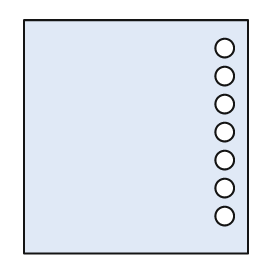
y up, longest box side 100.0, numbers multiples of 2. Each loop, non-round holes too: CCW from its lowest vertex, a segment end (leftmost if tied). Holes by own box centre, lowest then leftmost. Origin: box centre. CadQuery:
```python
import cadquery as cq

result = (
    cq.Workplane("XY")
    .moveTo(-48.0, -50.0)
    .lineTo(48.0, -50.0)
    .lineTo(48.0, 50.0)
    .lineTo(-48.0, 50.0)
    .close()
    .moveTo(38.0, -34.0)
    .circle(4.0)
    .moveTo(38.0, -22.0)
    .circle(4.0)
    .moveTo(38.0, -10.0)
    .circle(4.0)
    .moveTo(38.0, 2.0)
    .circle(4.0)
    .moveTo(38.0, 14.0)
    .circle(4.0)
    .moveTo(38.0, 26.0)
    .circle(4.0)
    .moveTo(38.0, 38.0)
    .circle(4.0)
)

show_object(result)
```